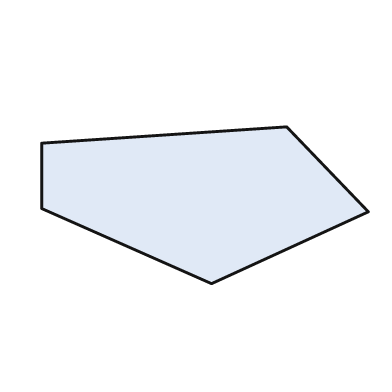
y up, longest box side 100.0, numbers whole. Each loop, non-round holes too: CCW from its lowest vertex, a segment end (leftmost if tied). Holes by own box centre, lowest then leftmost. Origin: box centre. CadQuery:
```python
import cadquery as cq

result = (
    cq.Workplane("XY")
    .moveTo(2.0, -24.0)
    .lineTo(50.0, -2.0)
    .lineTo(25.0, 24.0)
    .lineTo(-50.0, 19.0)
    .lineTo(-50.0, -1.0)
    .close()
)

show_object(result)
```